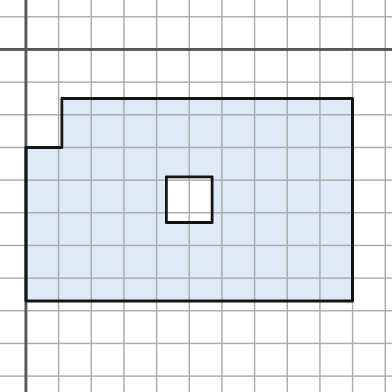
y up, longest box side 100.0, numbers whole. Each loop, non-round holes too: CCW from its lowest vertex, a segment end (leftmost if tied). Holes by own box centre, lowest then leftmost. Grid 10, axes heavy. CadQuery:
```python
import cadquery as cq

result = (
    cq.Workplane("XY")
    .moveTo(0.0, -77.0)
    .lineTo(100.0, -77.0)
    .lineTo(100.0, -15.0)
    .lineTo(11.0, -15.0)
    .lineTo(11.0, -30.0)
    .lineTo(0.0, -30.0)
    .close()
    .moveTo(43.0, -53.0)
    .lineTo(57.0, -53.0)
    .lineTo(57.0, -39.0)
    .lineTo(43.0, -39.0)
    .close()
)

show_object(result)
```